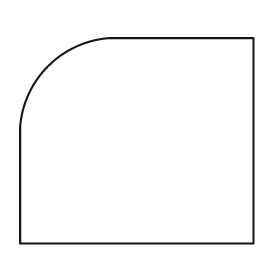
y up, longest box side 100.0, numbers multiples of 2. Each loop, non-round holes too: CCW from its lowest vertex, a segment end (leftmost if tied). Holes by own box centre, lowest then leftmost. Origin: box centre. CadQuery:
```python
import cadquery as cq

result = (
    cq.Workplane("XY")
    .moveTo(-50.0, -44.0)
    .lineTo(50.0, -44.0)
    .lineTo(50.0, 44.0)
    .lineTo(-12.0, 44.0)
    .threePointArc((-38.0, 32.0), (-50.0, 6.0))
    .close()
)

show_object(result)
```